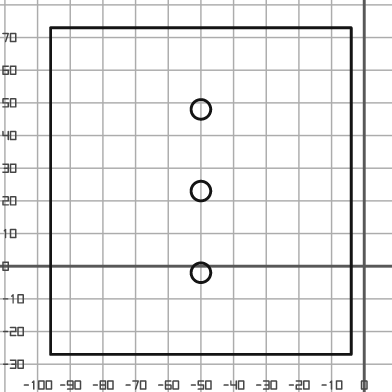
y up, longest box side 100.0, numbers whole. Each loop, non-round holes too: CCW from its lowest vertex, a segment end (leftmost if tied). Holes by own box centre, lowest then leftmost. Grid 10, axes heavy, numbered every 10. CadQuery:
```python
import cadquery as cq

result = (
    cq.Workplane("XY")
    .moveTo(-96.0, -27.0)
    .lineTo(-4.0, -27.0)
    .lineTo(-4.0, 73.0)
    .lineTo(-96.0, 73.0)
    .close()
    .moveTo(-50.0, -2.0)
    .circle(3.0)
    .moveTo(-50.0, 23.0)
    .circle(3.0)
    .moveTo(-50.0, 48.0)
    .circle(3.0)
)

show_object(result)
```